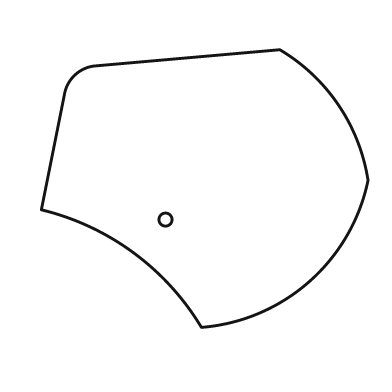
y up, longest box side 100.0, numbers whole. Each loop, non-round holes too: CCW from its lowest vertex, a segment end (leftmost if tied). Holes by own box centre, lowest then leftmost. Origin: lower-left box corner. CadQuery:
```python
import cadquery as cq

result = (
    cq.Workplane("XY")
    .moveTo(49.0, 0.0)
    .threePointArc((82.0, 14.0), (100.0, 45.0))
    .threePointArc((91.0, 68.0), (73.0, 85.0))
    .lineTo(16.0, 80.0)
    .threePointArc((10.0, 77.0), (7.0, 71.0))
    .lineTo(0.0, 36.0)
    .threePointArc((28.0, 23.0), (49.0, 0.0))
    .close()
    .moveTo(38.0, 33.0)
    .circle(2.0)
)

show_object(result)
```